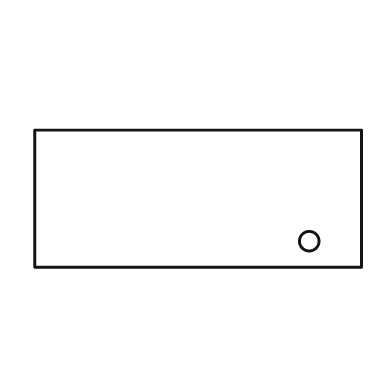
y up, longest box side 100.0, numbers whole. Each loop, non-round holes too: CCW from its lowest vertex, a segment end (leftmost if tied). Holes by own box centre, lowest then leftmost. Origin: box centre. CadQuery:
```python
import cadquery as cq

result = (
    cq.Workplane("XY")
    .moveTo(-50.0, -21.0)
    .lineTo(50.0, -21.0)
    .lineTo(50.0, 21.0)
    .lineTo(-50.0, 21.0)
    .close()
    .moveTo(34.0, -13.0)
    .circle(3.0)
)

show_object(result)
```